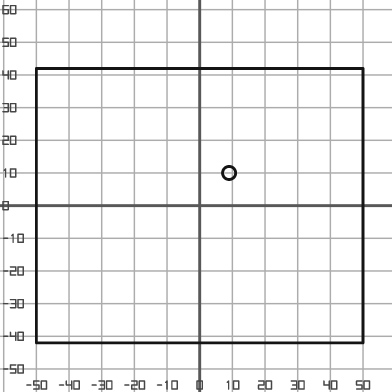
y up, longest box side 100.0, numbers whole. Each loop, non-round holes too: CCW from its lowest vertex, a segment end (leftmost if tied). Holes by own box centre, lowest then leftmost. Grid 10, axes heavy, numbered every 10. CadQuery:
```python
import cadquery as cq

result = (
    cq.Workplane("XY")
    .moveTo(-50.0, -42.0)
    .lineTo(50.0, -42.0)
    .lineTo(50.0, 42.0)
    .lineTo(-50.0, 42.0)
    .close()
    .moveTo(9.0, 10.0)
    .circle(2.0)
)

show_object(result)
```